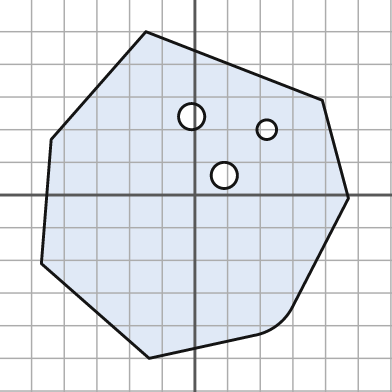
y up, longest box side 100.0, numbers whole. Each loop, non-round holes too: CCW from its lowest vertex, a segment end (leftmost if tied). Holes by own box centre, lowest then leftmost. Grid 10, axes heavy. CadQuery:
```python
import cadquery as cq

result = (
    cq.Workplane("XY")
    .moveTo(-14.0, -50.0)
    .lineTo(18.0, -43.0)
    .threePointArc((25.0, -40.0), (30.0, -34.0))
    .lineTo(47.0, -1.0)
    .lineTo(39.0, 29.0)
    .lineTo(-15.0, 50.0)
    .lineTo(-44.0, 17.0)
    .lineTo(-47.0, -21.0)
    .close()
    .moveTo(9.0, 6.0)
    .circle(4.0)
    .moveTo(22.0, 20.0)
    .circle(3.0)
    .moveTo(-1.0, 24.0)
    .circle(4.0)
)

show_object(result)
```